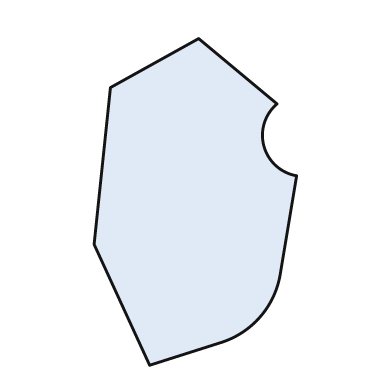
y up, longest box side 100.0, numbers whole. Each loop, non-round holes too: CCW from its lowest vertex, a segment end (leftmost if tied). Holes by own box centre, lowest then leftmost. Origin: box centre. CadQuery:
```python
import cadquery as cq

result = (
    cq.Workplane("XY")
    .moveTo(-14.0, -50.0)
    .lineTo(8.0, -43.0)
    .threePointArc((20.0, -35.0), (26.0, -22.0))
    .lineTo(31.0, 8.0)
    .threePointArc((21.0, 17.0), (25.0, 30.0))
    .lineTo(1.0, 50.0)
    .lineTo(-26.0, 35.0)
    .lineTo(-31.0, -13.0)
    .close()
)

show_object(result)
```